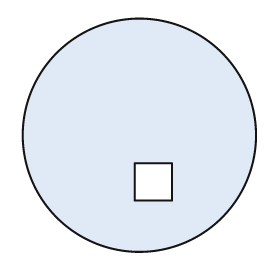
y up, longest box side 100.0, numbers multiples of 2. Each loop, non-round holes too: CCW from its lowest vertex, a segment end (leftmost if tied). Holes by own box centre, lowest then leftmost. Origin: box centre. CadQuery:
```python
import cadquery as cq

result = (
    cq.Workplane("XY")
    .moveTo(0.0, 0.0)
    .circle(50.0)
    .moveTo(-2.0, -28.0)
    .lineTo(14.0, -28.0)
    .lineTo(14.0, -12.0)
    .lineTo(-2.0, -12.0)
    .close()
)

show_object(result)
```